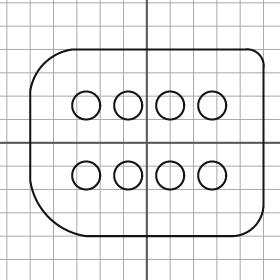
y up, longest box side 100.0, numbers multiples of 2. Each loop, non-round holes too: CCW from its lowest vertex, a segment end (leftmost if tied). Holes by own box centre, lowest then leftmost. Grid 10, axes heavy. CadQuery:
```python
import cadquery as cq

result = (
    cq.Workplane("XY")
    .moveTo(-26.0, -40.0)
    .lineTo(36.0, -40.0)
    .threePointArc((46.0, -36.0), (50.0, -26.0))
    .lineTo(50.0, 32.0)
    .threePointArc((48.0, 38.0), (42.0, 40.0))
    .lineTo(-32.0, 40.0)
    .threePointArc((-44.0, 34.0), (-50.0, 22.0))
    .lineTo(-50.0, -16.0)
    .threePointArc((-42.0, -32.0), (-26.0, -40.0))
    .close()
    .moveTo(-26.0, -14.0)
    .circle(6.0)
    .moveTo(-8.0, -14.0)
    .circle(6.0)
    .moveTo(10.0, -14.0)
    .circle(6.0)
    .moveTo(28.0, -14.0)
    .circle(6.0)
    .moveTo(-26.0, 16.0)
    .circle(6.0)
    .moveTo(-8.0, 16.0)
    .circle(6.0)
    .moveTo(10.0, 16.0)
    .circle(6.0)
    .moveTo(28.0, 16.0)
    .circle(6.0)
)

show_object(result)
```